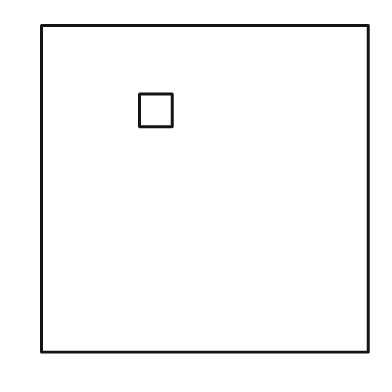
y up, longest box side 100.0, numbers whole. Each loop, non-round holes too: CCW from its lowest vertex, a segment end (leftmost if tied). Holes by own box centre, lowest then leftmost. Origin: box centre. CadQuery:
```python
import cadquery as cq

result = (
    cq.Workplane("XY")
    .moveTo(-50.0, -50.0)
    .lineTo(50.0, -50.0)
    .lineTo(50.0, 50.0)
    .lineTo(-50.0, 50.0)
    .close()
    .moveTo(-20.0, 19.0)
    .lineTo(-10.0, 19.0)
    .lineTo(-10.0, 29.0)
    .lineTo(-20.0, 29.0)
    .close()
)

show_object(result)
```